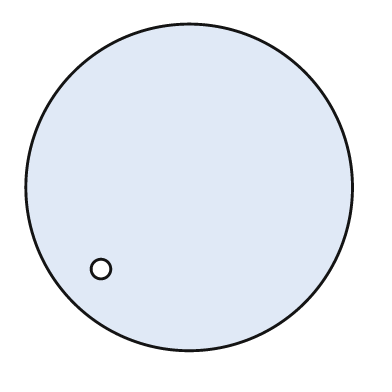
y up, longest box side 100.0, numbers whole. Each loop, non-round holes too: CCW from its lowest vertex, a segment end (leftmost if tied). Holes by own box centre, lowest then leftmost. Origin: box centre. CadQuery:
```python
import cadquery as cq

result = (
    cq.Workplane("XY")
    .moveTo(0.0, 0.0)
    .circle(50.0)
    .moveTo(-27.0, -25.0)
    .circle(3.0)
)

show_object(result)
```